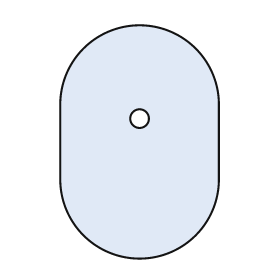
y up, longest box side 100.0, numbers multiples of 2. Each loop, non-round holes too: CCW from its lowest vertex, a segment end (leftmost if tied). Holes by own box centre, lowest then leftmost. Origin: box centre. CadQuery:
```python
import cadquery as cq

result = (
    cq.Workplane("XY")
    .moveTo(-34.0, -16.0)
    .threePointArc((0.0, -50.0), (34.0, -16.0))
    .lineTo(34.0, 16.0)
    .threePointArc((0.0, 50.0), (-34.0, 16.0))
    .close()
    .moveTo(0.0, 10.0)
    .circle(4.0)
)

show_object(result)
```